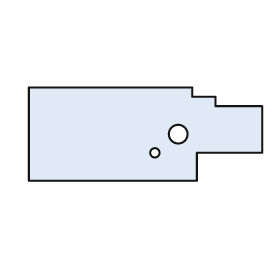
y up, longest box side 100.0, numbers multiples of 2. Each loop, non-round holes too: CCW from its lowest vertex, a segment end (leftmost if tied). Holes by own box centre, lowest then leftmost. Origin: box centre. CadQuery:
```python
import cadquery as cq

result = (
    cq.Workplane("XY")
    .moveTo(-50.0, -20.0)
    .lineTo(22.0, -20.0)
    .lineTo(22.0, -8.0)
    .lineTo(50.0, -8.0)
    .lineTo(50.0, 12.0)
    .lineTo(30.0, 12.0)
    .lineTo(30.0, 16.0)
    .lineTo(20.0, 16.0)
    .lineTo(20.0, 20.0)
    .lineTo(-50.0, 20.0)
    .close()
    .moveTo(4.0, -8.0)
    .circle(2.0)
    .moveTo(14.0, 0.0)
    .circle(4.0)
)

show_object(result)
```